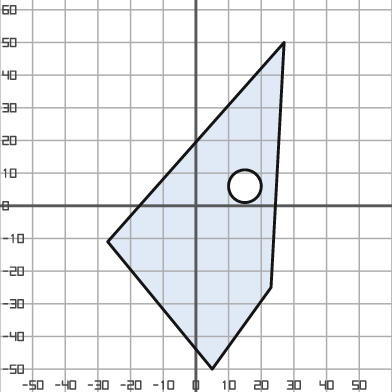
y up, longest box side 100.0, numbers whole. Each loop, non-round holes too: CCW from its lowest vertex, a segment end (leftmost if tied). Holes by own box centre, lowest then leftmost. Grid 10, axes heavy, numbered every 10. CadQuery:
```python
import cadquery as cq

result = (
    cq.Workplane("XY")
    .moveTo(5.0, -50.0)
    .lineTo(23.0, -25.0)
    .lineTo(27.0, 50.0)
    .lineTo(-27.0, -11.0)
    .close()
    .moveTo(15.0, 6.0)
    .circle(5.0)
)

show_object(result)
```